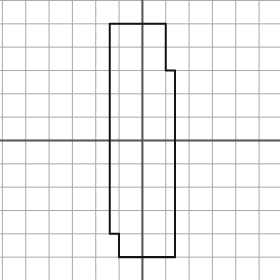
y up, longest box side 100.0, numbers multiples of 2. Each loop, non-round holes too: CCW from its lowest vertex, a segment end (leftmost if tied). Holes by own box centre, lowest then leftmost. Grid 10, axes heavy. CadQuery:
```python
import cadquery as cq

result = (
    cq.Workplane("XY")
    .moveTo(-10.0, -50.0)
    .lineTo(14.0, -50.0)
    .lineTo(14.0, 30.0)
    .lineTo(10.0, 30.0)
    .lineTo(10.0, 50.0)
    .lineTo(-14.0, 50.0)
    .lineTo(-14.0, -40.0)
    .lineTo(-10.0, -40.0)
    .close()
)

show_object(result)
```